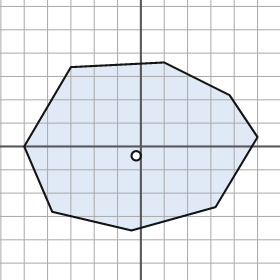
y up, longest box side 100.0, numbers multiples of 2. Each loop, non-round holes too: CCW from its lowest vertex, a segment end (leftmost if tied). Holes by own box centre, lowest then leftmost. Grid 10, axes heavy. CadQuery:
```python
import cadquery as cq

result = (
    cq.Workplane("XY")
    .moveTo(-4.0, -36.0)
    .lineTo(32.0, -26.0)
    .lineTo(50.0, 4.0)
    .lineTo(38.0, 22.0)
    .lineTo(10.0, 36.0)
    .lineTo(-30.0, 34.0)
    .lineTo(-50.0, 0.0)
    .lineTo(-38.0, -28.0)
    .close()
    .moveTo(-2.0, -4.0)
    .circle(2.0)
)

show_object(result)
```